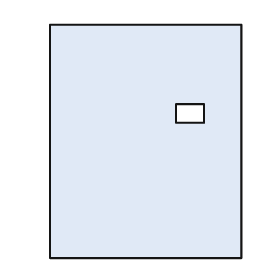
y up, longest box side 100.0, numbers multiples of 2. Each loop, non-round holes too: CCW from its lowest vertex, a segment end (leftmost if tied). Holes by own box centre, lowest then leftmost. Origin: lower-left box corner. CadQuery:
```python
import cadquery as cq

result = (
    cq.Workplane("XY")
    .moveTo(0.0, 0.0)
    .lineTo(82.0, 0.0)
    .lineTo(82.0, 100.0)
    .lineTo(0.0, 100.0)
    .close()
    .moveTo(54.0, 58.0)
    .lineTo(66.0, 58.0)
    .lineTo(66.0, 66.0)
    .lineTo(54.0, 66.0)
    .close()
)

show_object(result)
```